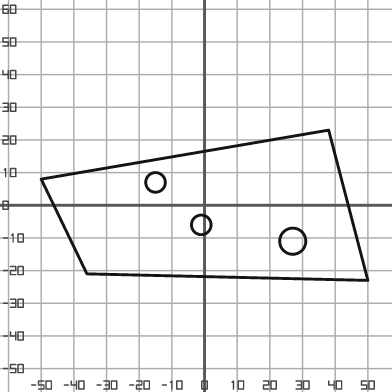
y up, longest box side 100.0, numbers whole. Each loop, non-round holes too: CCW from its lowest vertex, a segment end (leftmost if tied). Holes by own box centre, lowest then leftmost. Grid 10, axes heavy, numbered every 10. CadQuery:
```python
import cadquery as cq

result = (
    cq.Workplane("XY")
    .moveTo(50.0, -23.0)
    .lineTo(38.0, 23.0)
    .lineTo(-50.0, 8.0)
    .lineTo(-36.0, -21.0)
    .close()
    .moveTo(27.0, -11.0)
    .circle(4.0)
    .moveTo(-1.0, -6.0)
    .circle(3.0)
    .moveTo(-15.0, 7.0)
    .circle(3.0)
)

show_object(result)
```